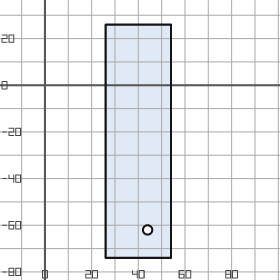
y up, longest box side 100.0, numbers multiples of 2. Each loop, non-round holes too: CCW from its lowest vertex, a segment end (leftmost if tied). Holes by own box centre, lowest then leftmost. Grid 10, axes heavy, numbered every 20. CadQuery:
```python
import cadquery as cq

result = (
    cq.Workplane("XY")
    .moveTo(26.0, -74.0)
    .lineTo(54.0, -74.0)
    .lineTo(54.0, 26.0)
    .lineTo(26.0, 26.0)
    .close()
    .moveTo(44.0, -62.0)
    .circle(2.0)
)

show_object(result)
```